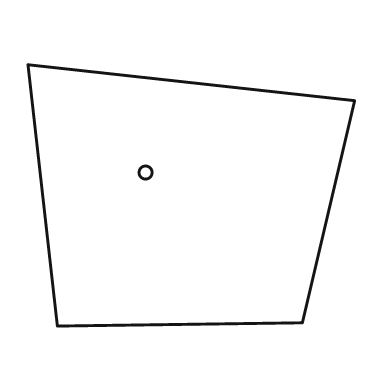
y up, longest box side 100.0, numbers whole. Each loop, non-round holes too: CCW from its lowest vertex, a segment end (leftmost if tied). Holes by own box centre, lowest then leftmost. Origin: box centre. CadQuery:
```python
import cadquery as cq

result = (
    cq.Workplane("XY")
    .moveTo(-41.0, -40.0)
    .lineTo(34.0, -39.0)
    .lineTo(50.0, 29.0)
    .lineTo(-50.0, 40.0)
    .close()
    .moveTo(-14.0, 7.0)
    .circle(2.0)
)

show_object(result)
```